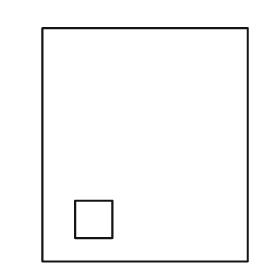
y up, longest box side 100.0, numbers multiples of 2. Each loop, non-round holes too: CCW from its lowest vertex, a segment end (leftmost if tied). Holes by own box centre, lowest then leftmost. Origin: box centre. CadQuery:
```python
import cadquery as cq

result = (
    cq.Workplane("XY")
    .moveTo(-44.0, -50.0)
    .lineTo(44.0, -50.0)
    .lineTo(44.0, 50.0)
    .lineTo(-44.0, 50.0)
    .close()
    .moveTo(-30.0, -40.0)
    .lineTo(-14.0, -40.0)
    .lineTo(-14.0, -24.0)
    .lineTo(-30.0, -24.0)
    .close()
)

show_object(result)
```